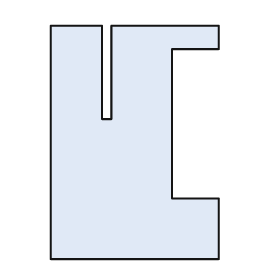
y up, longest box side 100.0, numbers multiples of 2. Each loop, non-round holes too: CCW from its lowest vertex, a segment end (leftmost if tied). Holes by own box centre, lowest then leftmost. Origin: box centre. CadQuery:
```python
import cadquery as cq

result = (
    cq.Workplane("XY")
    .moveTo(-36.0, -50.0)
    .lineTo(36.0, -50.0)
    .lineTo(36.0, -24.0)
    .lineTo(16.0, -24.0)
    .lineTo(16.0, 40.0)
    .lineTo(36.0, 40.0)
    .lineTo(36.0, 50.0)
    .lineTo(-10.0, 50.0)
    .lineTo(-10.0, 10.0)
    .lineTo(-14.0, 10.0)
    .lineTo(-14.0, 50.0)
    .lineTo(-36.0, 50.0)
    .close()
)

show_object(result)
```